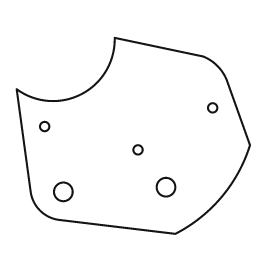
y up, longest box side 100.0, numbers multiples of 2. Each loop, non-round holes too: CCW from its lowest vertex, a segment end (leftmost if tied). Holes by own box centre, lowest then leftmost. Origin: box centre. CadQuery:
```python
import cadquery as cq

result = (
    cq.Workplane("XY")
    .moveTo(18.0, -42.0)
    .threePointArc((38.0, -26.0), (50.0, -4.0))
    .lineTo(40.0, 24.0)
    .threePointArc((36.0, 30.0), (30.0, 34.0))
    .lineTo(-8.0, 42.0)
    .threePointArc((-22.0, 18.0), (-50.0, 20.0))
    .lineTo(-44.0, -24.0)
    .threePointArc((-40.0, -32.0), (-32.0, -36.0))
    .close()
    .moveTo(-30.0, -24.0)
    .circle(4.0)
    .moveTo(14.0, -22.0)
    .circle(4.0)
    .moveTo(2.0, -6.0)
    .circle(2.0)
    .moveTo(-38.0, 4.0)
    .circle(2.0)
    .moveTo(34.0, 12.0)
    .circle(2.0)
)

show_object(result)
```